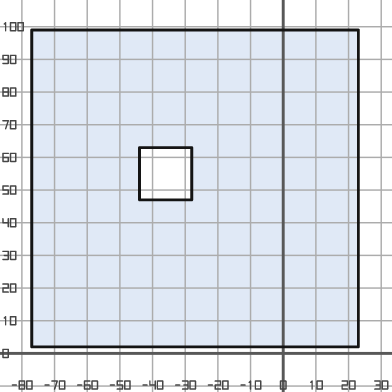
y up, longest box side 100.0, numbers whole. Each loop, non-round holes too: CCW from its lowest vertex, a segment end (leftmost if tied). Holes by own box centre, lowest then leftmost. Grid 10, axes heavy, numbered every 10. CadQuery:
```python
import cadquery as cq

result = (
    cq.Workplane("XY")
    .moveTo(-77.0, 2.0)
    .lineTo(23.0, 2.0)
    .lineTo(23.0, 99.0)
    .lineTo(-77.0, 99.0)
    .close()
    .moveTo(-44.0, 47.0)
    .lineTo(-28.0, 47.0)
    .lineTo(-28.0, 63.0)
    .lineTo(-44.0, 63.0)
    .close()
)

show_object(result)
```